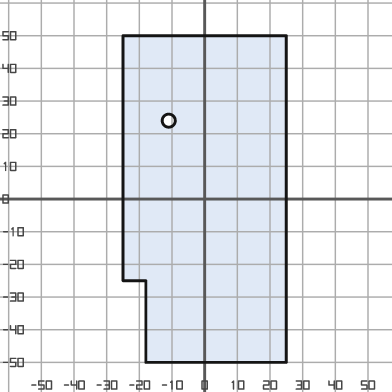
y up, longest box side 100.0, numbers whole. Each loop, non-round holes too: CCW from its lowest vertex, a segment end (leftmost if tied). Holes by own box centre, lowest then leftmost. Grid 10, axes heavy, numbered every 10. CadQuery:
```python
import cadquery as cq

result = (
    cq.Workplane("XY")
    .moveTo(-18.0, -50.0)
    .lineTo(25.0, -50.0)
    .lineTo(25.0, 50.0)
    .lineTo(-25.0, 50.0)
    .lineTo(-25.0, -25.0)
    .lineTo(-18.0, -25.0)
    .close()
    .moveTo(-11.0, 24.0)
    .circle(2.0)
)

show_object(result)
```